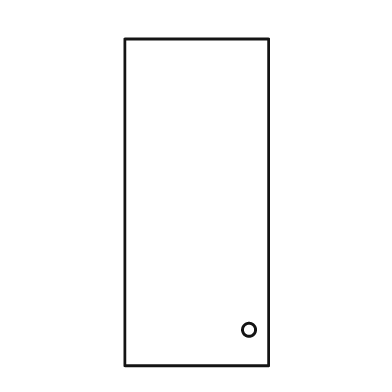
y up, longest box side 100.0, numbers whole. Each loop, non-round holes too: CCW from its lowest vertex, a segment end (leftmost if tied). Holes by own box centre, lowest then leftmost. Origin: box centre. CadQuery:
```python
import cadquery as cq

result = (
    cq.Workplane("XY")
    .moveTo(-22.0, -50.0)
    .lineTo(22.0, -50.0)
    .lineTo(22.0, 50.0)
    .lineTo(-22.0, 50.0)
    .close()
    .moveTo(16.0, -39.0)
    .circle(2.0)
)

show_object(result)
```